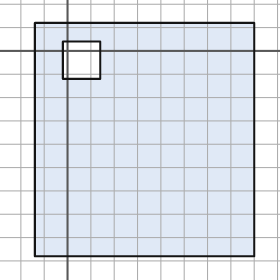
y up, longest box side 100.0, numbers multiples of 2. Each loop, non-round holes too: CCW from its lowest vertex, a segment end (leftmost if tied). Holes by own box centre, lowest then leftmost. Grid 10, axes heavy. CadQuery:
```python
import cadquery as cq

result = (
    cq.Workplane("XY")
    .moveTo(-14.0, -88.0)
    .lineTo(80.0, -88.0)
    .lineTo(80.0, 12.0)
    .lineTo(-14.0, 12.0)
    .close()
    .moveTo(-2.0, -12.0)
    .lineTo(14.0, -12.0)
    .lineTo(14.0, 4.0)
    .lineTo(-2.0, 4.0)
    .close()
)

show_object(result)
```